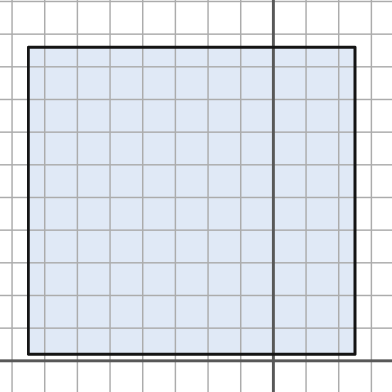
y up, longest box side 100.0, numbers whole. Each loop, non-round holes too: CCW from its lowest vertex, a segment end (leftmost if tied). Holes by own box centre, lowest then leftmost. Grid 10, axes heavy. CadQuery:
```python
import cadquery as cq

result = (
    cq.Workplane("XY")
    .moveTo(-75.0, 2.0)
    .lineTo(25.0, 2.0)
    .lineTo(25.0, 96.0)
    .lineTo(-75.0, 96.0)
    .close()
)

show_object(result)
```